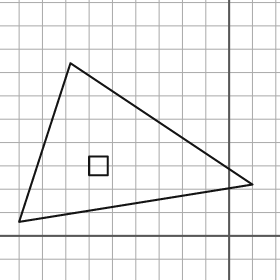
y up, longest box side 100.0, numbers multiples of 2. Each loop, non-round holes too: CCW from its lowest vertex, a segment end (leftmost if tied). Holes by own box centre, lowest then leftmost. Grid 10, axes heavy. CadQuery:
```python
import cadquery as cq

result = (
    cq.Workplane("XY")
    .moveTo(-90.0, 6.0)
    .lineTo(10.0, 22.0)
    .lineTo(-68.0, 74.0)
    .close()
    .moveTo(-60.0, 26.0)
    .lineTo(-52.0, 26.0)
    .lineTo(-52.0, 34.0)
    .lineTo(-60.0, 34.0)
    .close()
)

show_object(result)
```